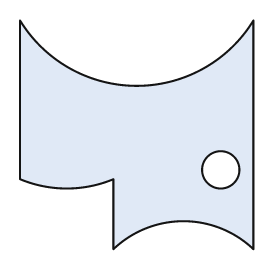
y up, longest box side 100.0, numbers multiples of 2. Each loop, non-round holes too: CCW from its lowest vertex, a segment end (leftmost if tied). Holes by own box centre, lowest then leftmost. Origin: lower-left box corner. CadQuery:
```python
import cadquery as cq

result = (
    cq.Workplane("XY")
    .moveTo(40.0, 0.0)
    .threePointArc((70.0, 12.0), (100.0, 0.0))
    .lineTo(100.0, 98.0)
    .threePointArc((50.0, 70.0), (0.0, 98.0))
    .lineTo(0.0, 30.0)
    .threePointArc((20.0, 26.0), (40.0, 30.0))
    .close()
    .moveTo(86.0, 34.0)
    .circle(8.0)
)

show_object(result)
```